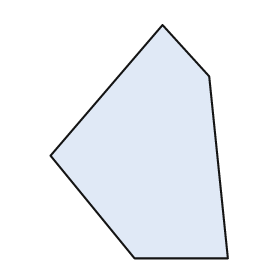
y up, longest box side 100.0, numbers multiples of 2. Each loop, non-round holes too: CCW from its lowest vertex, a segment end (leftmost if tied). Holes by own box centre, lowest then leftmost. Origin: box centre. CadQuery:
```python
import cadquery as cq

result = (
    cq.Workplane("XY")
    .moveTo(-2.0, -50.0)
    .lineTo(38.0, -50.0)
    .lineTo(30.0, 28.0)
    .lineTo(10.0, 50.0)
    .lineTo(-38.0, -6.0)
    .close()
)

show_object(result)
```